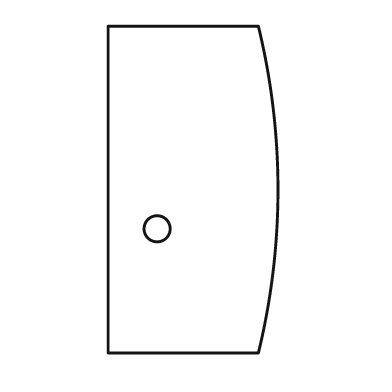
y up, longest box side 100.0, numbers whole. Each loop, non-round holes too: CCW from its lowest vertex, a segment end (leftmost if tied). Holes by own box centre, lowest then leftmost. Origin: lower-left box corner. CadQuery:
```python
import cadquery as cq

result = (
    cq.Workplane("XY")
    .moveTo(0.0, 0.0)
    .lineTo(46.0, 0.0)
    .threePointArc((52.0, 50.0), (46.0, 100.0))
    .lineTo(0.0, 100.0)
    .close()
    .moveTo(15.0, 38.0)
    .circle(4.0)
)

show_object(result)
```